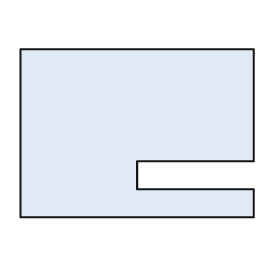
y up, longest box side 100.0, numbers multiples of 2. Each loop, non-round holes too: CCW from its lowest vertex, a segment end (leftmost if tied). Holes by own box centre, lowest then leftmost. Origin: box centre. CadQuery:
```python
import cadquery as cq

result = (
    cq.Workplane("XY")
    .moveTo(-50.0, -36.0)
    .lineTo(50.0, -36.0)
    .lineTo(50.0, -24.0)
    .lineTo(0.0, -24.0)
    .lineTo(0.0, -12.0)
    .lineTo(50.0, -12.0)
    .lineTo(50.0, 36.0)
    .lineTo(-50.0, 36.0)
    .close()
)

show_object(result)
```